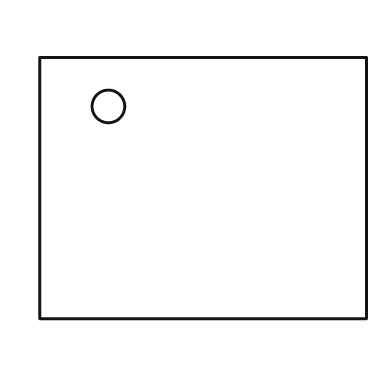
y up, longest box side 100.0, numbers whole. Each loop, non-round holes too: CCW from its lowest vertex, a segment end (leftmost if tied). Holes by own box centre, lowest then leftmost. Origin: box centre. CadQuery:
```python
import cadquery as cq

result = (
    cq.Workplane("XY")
    .moveTo(-50.0, -40.0)
    .lineTo(50.0, -40.0)
    .lineTo(50.0, 40.0)
    .lineTo(-50.0, 40.0)
    .close()
    .moveTo(-29.0, 25.0)
    .circle(5.0)
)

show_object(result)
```